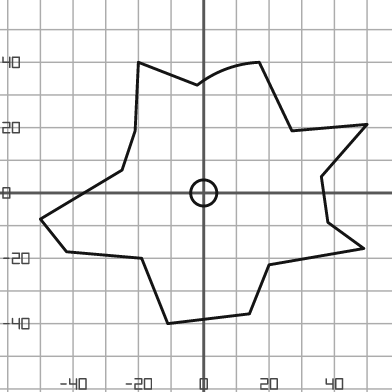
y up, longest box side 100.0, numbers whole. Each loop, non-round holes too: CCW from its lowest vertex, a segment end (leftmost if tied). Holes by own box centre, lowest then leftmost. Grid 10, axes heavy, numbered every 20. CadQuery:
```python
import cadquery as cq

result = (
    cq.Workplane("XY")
    .moveTo(-11.0, -40.0)
    .lineTo(14.0, -37.0)
    .lineTo(20.0, -22.0)
    .lineTo(49.0, -17.0)
    .lineTo(38.0, -9.0)
    .lineTo(36.0, 5.0)
    .lineTo(50.0, 21.0)
    .lineTo(27.0, 19.0)
    .lineTo(17.0, 40.0)
    .threePointArc((7.0, 38.0), (-2.0, 33.0))
    .lineTo(-20.0, 40.0)
    .lineTo(-21.0, 19.0)
    .lineTo(-25.0, 7.0)
    .lineTo(-50.0, -8.0)
    .lineTo(-42.0, -18.0)
    .lineTo(-19.0, -20.0)
    .close()
    .moveTo(0.0, 0.0)
    .circle(4.0)
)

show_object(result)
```